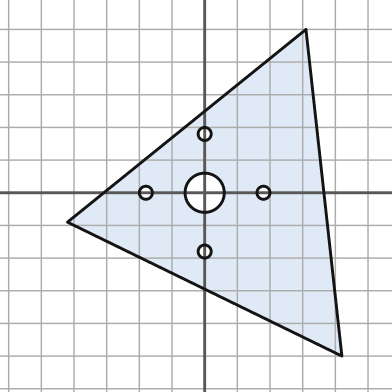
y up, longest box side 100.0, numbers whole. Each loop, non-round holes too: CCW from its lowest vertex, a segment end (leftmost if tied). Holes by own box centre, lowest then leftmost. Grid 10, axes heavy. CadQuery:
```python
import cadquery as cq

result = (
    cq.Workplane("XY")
    .moveTo(42.0, -50.0)
    .lineTo(31.0, 50.0)
    .lineTo(-42.0, -9.0)
    .close()
    .moveTo(0.0, -18.0)
    .circle(2.0)
    .moveTo(-18.0, 0.0)
    .circle(2.0)
    .moveTo(0.0, 0.0)
    .circle(6.0)
    .moveTo(18.0, 0.0)
    .circle(2.0)
    .moveTo(0.0, 18.0)
    .circle(2.0)
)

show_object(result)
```